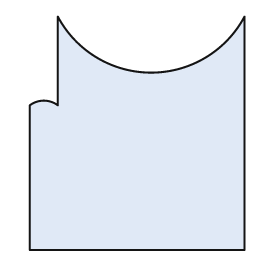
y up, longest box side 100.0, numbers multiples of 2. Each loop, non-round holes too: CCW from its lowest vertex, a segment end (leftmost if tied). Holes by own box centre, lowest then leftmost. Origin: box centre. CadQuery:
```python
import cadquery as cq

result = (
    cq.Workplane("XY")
    .moveTo(-46.0, -50.0)
    .lineTo(46.0, -50.0)
    .lineTo(46.0, 50.0)
    .threePointArc((6.0, 26.0), (-34.0, 50.0))
    .lineTo(-34.0, 12.0)
    .threePointArc((-40.0, 14.0), (-46.0, 12.0))
    .close()
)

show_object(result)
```